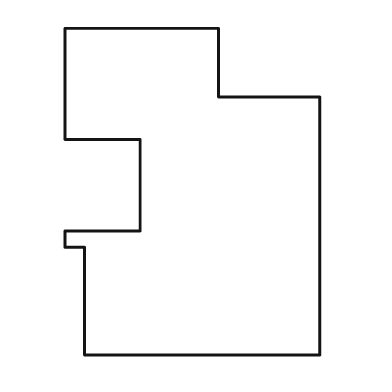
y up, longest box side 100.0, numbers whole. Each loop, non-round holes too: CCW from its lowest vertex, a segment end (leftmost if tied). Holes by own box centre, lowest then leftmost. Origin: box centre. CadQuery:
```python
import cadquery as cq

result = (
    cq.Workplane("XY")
    .moveTo(-33.0, -50.0)
    .lineTo(39.0, -50.0)
    .lineTo(39.0, 29.0)
    .lineTo(8.0, 29.0)
    .lineTo(8.0, 50.0)
    .lineTo(-39.0, 50.0)
    .lineTo(-39.0, 16.0)
    .lineTo(-16.0, 16.0)
    .lineTo(-16.0, -12.0)
    .lineTo(-39.0, -12.0)
    .lineTo(-39.0, -17.0)
    .lineTo(-33.0, -17.0)
    .close()
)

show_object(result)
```